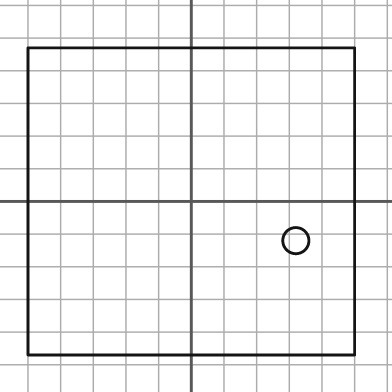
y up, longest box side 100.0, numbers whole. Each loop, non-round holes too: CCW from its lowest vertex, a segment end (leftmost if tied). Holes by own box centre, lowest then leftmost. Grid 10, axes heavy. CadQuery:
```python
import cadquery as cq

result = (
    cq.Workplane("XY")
    .moveTo(-50.0, -47.0)
    .lineTo(50.0, -47.0)
    .lineTo(50.0, 47.0)
    .lineTo(-50.0, 47.0)
    .close()
    .moveTo(32.0, -12.0)
    .circle(4.0)
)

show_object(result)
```